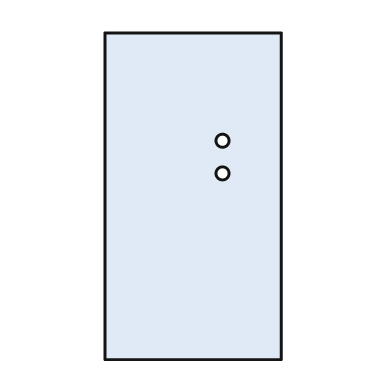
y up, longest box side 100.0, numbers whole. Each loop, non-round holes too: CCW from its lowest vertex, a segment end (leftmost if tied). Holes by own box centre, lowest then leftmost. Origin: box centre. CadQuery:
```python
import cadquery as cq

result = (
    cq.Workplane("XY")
    .moveTo(-27.0, -50.0)
    .lineTo(27.0, -50.0)
    .lineTo(27.0, 50.0)
    .lineTo(-27.0, 50.0)
    .close()
    .moveTo(9.0, 7.0)
    .circle(2.0)
    .moveTo(9.0, 17.0)
    .circle(2.0)
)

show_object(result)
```